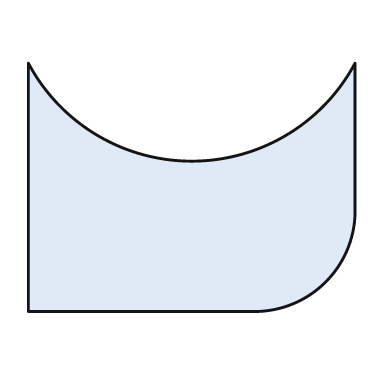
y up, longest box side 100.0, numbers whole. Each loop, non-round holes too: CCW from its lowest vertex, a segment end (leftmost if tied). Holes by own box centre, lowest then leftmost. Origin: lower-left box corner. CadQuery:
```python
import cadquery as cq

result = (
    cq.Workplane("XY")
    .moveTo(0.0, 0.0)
    .lineTo(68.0, 0.0)
    .threePointArc((91.0, 9.0), (100.0, 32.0))
    .lineTo(100.0, 76.0)
    .threePointArc((50.0, 46.0), (0.0, 76.0))
    .close()
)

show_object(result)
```